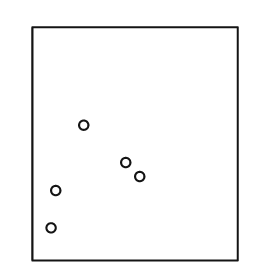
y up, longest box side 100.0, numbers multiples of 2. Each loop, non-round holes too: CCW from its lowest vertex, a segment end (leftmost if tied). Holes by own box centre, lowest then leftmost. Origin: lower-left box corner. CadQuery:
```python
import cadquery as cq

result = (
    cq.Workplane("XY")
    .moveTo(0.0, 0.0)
    .lineTo(88.0, 0.0)
    .lineTo(88.0, 100.0)
    .lineTo(0.0, 100.0)
    .close()
    .moveTo(8.0, 14.0)
    .circle(2.0)
    .moveTo(10.0, 30.0)
    .circle(2.0)
    .moveTo(46.0, 36.0)
    .circle(2.0)
    .moveTo(40.0, 42.0)
    .circle(2.0)
    .moveTo(22.0, 58.0)
    .circle(2.0)
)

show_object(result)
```